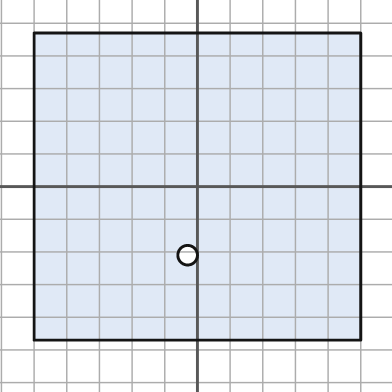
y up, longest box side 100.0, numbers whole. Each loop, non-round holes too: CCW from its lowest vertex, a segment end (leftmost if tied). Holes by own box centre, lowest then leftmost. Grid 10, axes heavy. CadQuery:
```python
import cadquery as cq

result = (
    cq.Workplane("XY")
    .moveTo(-50.0, -47.0)
    .lineTo(50.0, -47.0)
    .lineTo(50.0, 47.0)
    .lineTo(-50.0, 47.0)
    .close()
    .moveTo(-3.0, -21.0)
    .circle(3.0)
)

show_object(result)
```